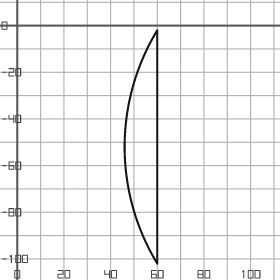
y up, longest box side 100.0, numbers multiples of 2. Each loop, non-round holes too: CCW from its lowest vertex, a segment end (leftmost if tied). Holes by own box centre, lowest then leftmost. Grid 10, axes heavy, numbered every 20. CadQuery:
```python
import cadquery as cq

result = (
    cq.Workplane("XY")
    .moveTo(60.0, -102.0)
    .lineTo(60.0, -2.0)
    .threePointArc((46.0, -52.0), (60.0, -102.0))
    .close()
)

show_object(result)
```